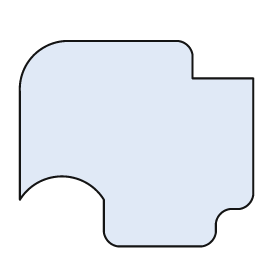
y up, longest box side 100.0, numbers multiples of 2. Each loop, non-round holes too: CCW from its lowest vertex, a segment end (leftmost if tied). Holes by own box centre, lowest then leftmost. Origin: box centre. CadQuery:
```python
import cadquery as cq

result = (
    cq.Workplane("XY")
    .moveTo(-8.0, -44.0)
    .lineTo(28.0, -44.0)
    .threePointArc((32.0, -42.0), (34.0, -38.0))
    .lineTo(34.0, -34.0)
    .threePointArc((36.0, -30.0), (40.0, -28.0))
    .lineTo(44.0, -28.0)
    .threePointArc((48.0, -26.0), (50.0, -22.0))
    .lineTo(50.0, 28.0)
    .lineTo(24.0, 28.0)
    .lineTo(24.0, 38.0)
    .threePointArc((22.0, 42.0), (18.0, 44.0))
    .lineTo(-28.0, 44.0)
    .threePointArc((-44.0, 38.0), (-50.0, 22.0))
    .lineTo(-50.0, -24.0)
    .threePointArc((-32.0, -14.0), (-14.0, -24.0))
    .lineTo(-14.0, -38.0)
    .threePointArc((-12.0, -42.0), (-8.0, -44.0))
    .close()
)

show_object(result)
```